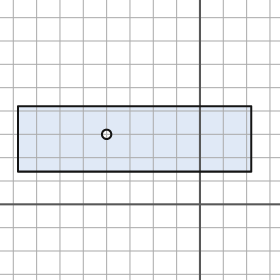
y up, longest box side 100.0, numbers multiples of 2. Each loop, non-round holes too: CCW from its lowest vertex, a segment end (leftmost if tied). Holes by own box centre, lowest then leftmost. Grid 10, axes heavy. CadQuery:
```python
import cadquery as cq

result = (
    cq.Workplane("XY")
    .moveTo(-78.0, 14.0)
    .lineTo(22.0, 14.0)
    .lineTo(22.0, 42.0)
    .lineTo(-78.0, 42.0)
    .close()
    .moveTo(-40.0, 30.0)
    .circle(2.0)
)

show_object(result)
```